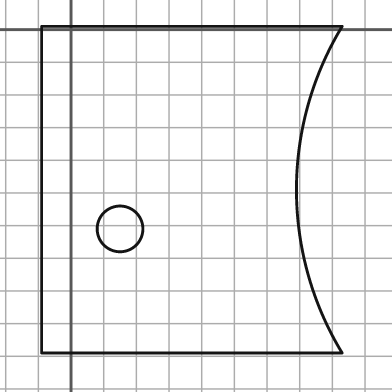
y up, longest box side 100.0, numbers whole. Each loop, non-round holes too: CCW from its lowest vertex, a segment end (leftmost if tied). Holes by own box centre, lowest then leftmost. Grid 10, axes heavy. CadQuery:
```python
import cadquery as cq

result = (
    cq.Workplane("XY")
    .moveTo(-9.0, -99.0)
    .lineTo(83.0, -99.0)
    .threePointArc((69.0, -49.0), (83.0, 1.0))
    .lineTo(-9.0, 1.0)
    .close()
    .moveTo(15.0, -61.0)
    .circle(7.0)
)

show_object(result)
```